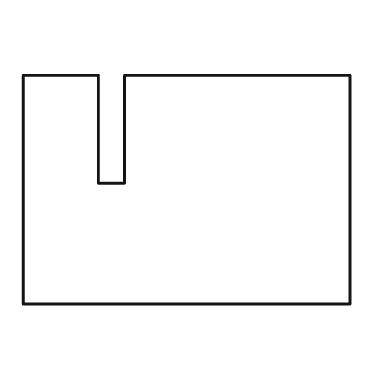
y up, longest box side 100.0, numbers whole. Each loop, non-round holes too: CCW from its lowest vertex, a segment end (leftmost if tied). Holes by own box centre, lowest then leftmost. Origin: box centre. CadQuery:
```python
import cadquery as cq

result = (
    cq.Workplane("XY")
    .moveTo(-50.0, -35.0)
    .lineTo(50.0, -35.0)
    .lineTo(50.0, 35.0)
    .lineTo(-19.0, 35.0)
    .lineTo(-19.0, 2.0)
    .lineTo(-27.0, 2.0)
    .lineTo(-27.0, 35.0)
    .lineTo(-50.0, 35.0)
    .close()
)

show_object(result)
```